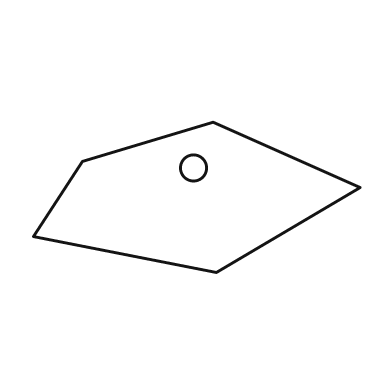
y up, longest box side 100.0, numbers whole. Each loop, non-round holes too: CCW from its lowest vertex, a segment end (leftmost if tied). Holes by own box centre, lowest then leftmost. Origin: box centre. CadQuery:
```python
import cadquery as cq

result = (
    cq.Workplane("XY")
    .moveTo(6.0, -23.0)
    .lineTo(50.0, 3.0)
    .lineTo(5.0, 23.0)
    .lineTo(-35.0, 11.0)
    .lineTo(-50.0, -12.0)
    .close()
    .moveTo(-1.0, 9.0)
    .circle(4.0)
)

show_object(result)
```